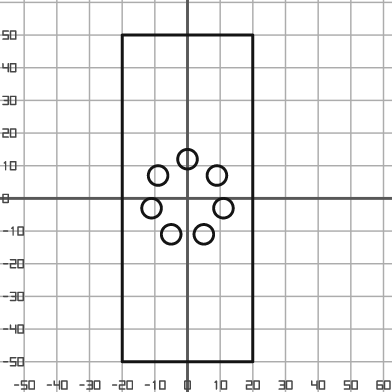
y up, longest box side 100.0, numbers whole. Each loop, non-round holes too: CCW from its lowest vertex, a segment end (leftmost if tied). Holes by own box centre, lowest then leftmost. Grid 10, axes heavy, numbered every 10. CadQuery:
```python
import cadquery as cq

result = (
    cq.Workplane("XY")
    .moveTo(-20.0, -50.0)
    .lineTo(20.0, -50.0)
    .lineTo(20.0, 50.0)
    .lineTo(-20.0, 50.0)
    .close()
    .moveTo(-5.0, -11.0)
    .circle(3.0)
    .moveTo(5.0, -11.0)
    .circle(3.0)
    .moveTo(-11.0, -3.0)
    .circle(3.0)
    .moveTo(11.0, -3.0)
    .circle(3.0)
    .moveTo(-9.0, 7.0)
    .circle(3.0)
    .moveTo(9.0, 7.0)
    .circle(3.0)
    .moveTo(0.0, 12.0)
    .circle(3.0)
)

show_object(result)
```